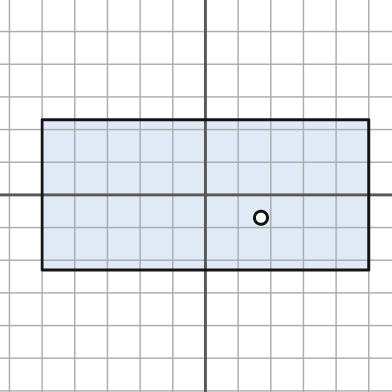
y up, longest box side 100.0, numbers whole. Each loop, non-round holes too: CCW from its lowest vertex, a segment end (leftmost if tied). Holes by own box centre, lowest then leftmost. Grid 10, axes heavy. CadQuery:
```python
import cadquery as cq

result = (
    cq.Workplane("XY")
    .moveTo(-50.0, -23.0)
    .lineTo(50.0, -23.0)
    .lineTo(50.0, 23.0)
    .lineTo(-50.0, 23.0)
    .close()
    .moveTo(17.0, -7.0)
    .circle(2.0)
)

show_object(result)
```